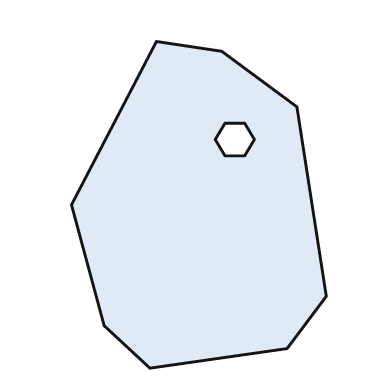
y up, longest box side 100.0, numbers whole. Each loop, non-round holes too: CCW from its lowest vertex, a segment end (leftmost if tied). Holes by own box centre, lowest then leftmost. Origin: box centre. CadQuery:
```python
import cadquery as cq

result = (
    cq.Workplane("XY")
    .moveTo(-15.0, -50.0)
    .lineTo(27.0, -44.0)
    .lineTo(39.0, -28.0)
    .lineTo(30.0, 30.0)
    .lineTo(7.0, 47.0)
    .lineTo(-13.0, 50.0)
    .lineTo(-39.0, 0.0)
    .lineTo(-29.0, -37.0)
    .close()
    .moveTo(8.0, 15.0)
    .lineTo(14.0, 15.0)
    .lineTo(17.0, 20.0)
    .lineTo(14.0, 25.0)
    .lineTo(8.0, 25.0)
    .lineTo(5.0, 20.0)
    .close()
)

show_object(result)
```